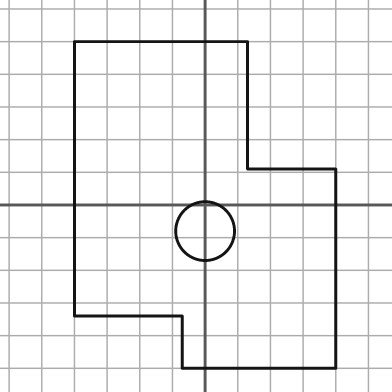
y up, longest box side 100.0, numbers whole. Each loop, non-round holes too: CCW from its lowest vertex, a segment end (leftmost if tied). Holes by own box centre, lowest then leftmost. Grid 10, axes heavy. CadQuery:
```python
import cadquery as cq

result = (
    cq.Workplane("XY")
    .moveTo(-7.0, -50.0)
    .lineTo(40.0, -50.0)
    .lineTo(40.0, 11.0)
    .lineTo(13.0, 11.0)
    .lineTo(13.0, 50.0)
    .lineTo(-40.0, 50.0)
    .lineTo(-40.0, -34.0)
    .lineTo(-7.0, -34.0)
    .close()
    .moveTo(0.0, -8.0)
    .circle(9.0)
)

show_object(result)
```